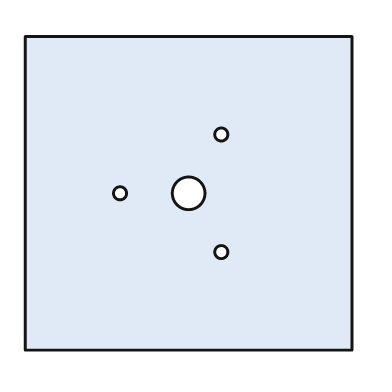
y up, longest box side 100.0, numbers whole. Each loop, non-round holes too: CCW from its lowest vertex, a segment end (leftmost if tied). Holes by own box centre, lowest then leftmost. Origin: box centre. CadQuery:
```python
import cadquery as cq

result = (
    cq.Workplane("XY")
    .moveTo(-50.0, -48.0)
    .lineTo(50.0, -48.0)
    .lineTo(50.0, 48.0)
    .lineTo(-50.0, 48.0)
    .close()
    .moveTo(10.0, -18.0)
    .circle(2.0)
    .moveTo(-21.0, 0.0)
    .circle(2.0)
    .moveTo(0.0, 0.0)
    .circle(5.0)
    .moveTo(10.0, 18.0)
    .circle(2.0)
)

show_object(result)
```